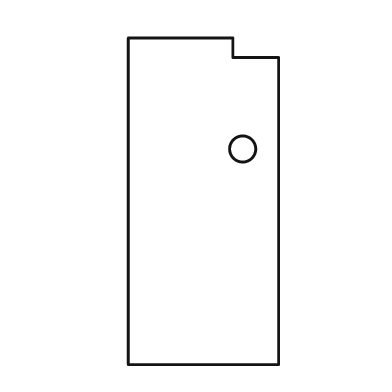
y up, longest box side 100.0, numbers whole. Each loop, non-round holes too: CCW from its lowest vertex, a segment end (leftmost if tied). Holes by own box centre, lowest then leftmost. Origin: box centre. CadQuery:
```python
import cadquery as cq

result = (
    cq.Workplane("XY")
    .moveTo(-23.0, -50.0)
    .lineTo(23.0, -50.0)
    .lineTo(23.0, 44.0)
    .lineTo(9.0, 44.0)
    .lineTo(9.0, 50.0)
    .lineTo(-23.0, 50.0)
    .close()
    .moveTo(12.0, 16.0)
    .circle(4.0)
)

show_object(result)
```